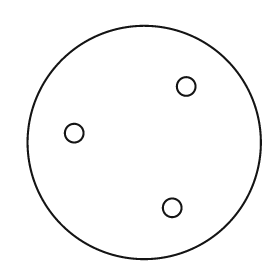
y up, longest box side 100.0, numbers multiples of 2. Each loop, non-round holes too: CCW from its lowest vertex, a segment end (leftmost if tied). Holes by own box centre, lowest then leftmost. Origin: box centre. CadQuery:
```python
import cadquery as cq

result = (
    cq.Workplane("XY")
    .moveTo(0.0, 0.0)
    .circle(50.0)
    .moveTo(12.0, -28.0)
    .circle(4.0)
    .moveTo(-30.0, 4.0)
    .circle(4.0)
    .moveTo(18.0, 24.0)
    .circle(4.0)
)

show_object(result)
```